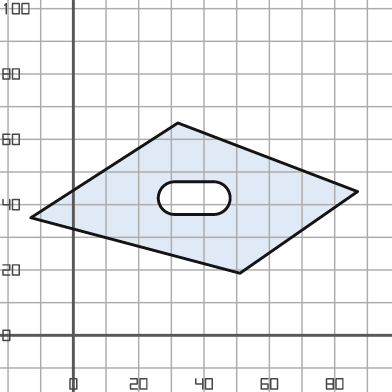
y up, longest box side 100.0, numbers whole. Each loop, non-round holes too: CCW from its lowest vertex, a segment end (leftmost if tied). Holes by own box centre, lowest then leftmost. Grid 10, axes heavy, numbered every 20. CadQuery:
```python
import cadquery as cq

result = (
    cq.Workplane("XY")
    .moveTo(51.0, 19.0)
    .lineTo(87.0, 44.0)
    .lineTo(32.0, 65.0)
    .lineTo(-13.0, 36.0)
    .close()
    .moveTo(31.0, 37.0)
    .lineTo(43.0, 37.0)
    .threePointArc((48.0, 42.0), (43.0, 47.0))
    .lineTo(31.0, 47.0)
    .threePointArc((26.0, 42.0), (31.0, 37.0))
    .close()
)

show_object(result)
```